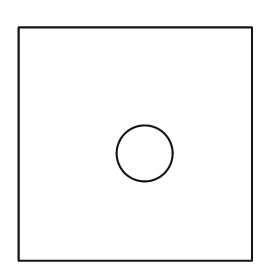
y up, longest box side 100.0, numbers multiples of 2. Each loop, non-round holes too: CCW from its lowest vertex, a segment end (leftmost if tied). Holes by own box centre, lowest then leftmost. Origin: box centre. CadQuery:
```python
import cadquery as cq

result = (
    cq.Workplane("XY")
    .moveTo(-50.0, -50.0)
    .lineTo(50.0, -50.0)
    .lineTo(50.0, 50.0)
    .lineTo(-50.0, 50.0)
    .close()
    .moveTo(4.0, -4.0)
    .circle(12.0)
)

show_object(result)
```